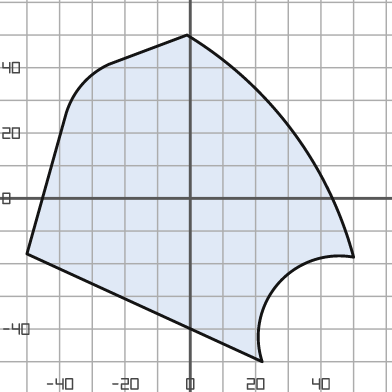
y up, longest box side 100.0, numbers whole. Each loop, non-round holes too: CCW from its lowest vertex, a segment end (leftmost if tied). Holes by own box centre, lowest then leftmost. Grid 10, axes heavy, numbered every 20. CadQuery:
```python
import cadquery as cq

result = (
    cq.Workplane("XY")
    .moveTo(22.0, -50.0)
    .threePointArc((27.0, -26.0), (50.0, -18.0))
    .threePointArc((31.0, 21.0), (-1.0, 50.0))
    .lineTo(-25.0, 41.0)
    .threePointArc((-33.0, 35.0), (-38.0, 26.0))
    .lineTo(-50.0, -17.0)
    .close()
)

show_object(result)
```